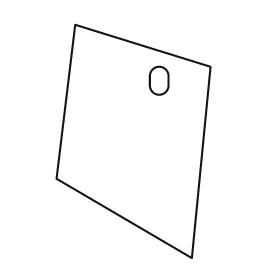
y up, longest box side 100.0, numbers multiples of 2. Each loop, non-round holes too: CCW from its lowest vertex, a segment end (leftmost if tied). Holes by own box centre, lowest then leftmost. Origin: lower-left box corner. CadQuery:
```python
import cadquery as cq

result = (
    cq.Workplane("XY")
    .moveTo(58.0, 0.0)
    .lineTo(66.0, 82.0)
    .lineTo(8.0, 100.0)
    .lineTo(0.0, 34.0)
    .close()
    .moveTo(40.0, 74.0)
    .threePointArc((44.0, 70.0), (48.0, 74.0))
    .lineTo(48.0, 78.0)
    .threePointArc((44.0, 82.0), (40.0, 78.0))
    .close()
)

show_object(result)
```